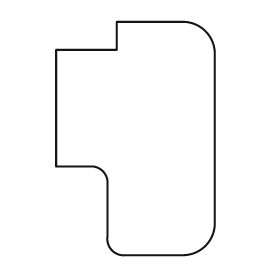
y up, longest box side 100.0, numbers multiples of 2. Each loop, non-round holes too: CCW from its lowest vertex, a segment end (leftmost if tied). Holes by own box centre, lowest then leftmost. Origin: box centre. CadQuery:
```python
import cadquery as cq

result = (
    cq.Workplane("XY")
    .moveTo(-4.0, -50.0)
    .lineTo(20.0, -50.0)
    .threePointArc((30.0, -46.0), (34.0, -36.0))
    .lineTo(34.0, 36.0)
    .threePointArc((30.0, 46.0), (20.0, 50.0))
    .lineTo(-8.0, 50.0)
    .lineTo(-8.0, 38.0)
    .lineTo(-34.0, 38.0)
    .lineTo(-34.0, -12.0)
    .lineTo(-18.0, -12.0)
    .threePointArc((-14.0, -14.0), (-12.0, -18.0))
    .lineTo(-12.0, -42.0)
    .threePointArc((-10.0, -48.0), (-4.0, -50.0))
    .close()
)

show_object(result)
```